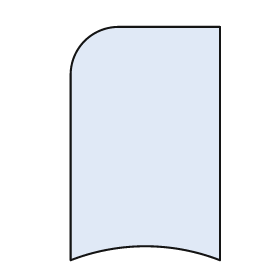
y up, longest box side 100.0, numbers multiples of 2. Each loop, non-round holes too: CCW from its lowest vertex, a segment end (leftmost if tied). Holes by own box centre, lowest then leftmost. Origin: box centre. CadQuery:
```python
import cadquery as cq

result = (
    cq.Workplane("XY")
    .moveTo(-32.0, -50.0)
    .threePointArc((0.0, -44.0), (32.0, -50.0))
    .lineTo(32.0, 50.0)
    .lineTo(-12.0, 50.0)
    .threePointArc((-26.0, 44.0), (-32.0, 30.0))
    .close()
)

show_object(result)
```